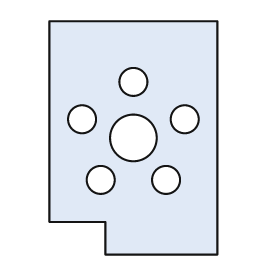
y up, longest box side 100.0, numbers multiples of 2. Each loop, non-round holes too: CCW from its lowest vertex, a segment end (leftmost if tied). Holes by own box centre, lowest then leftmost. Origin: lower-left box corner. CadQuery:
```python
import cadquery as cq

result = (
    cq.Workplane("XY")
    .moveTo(24.0, 0.0)
    .lineTo(72.0, 0.0)
    .lineTo(72.0, 100.0)
    .lineTo(0.0, 100.0)
    .lineTo(0.0, 14.0)
    .lineTo(24.0, 14.0)
    .close()
    .moveTo(22.0, 32.0)
    .circle(6.0)
    .moveTo(50.0, 32.0)
    .circle(6.0)
    .moveTo(36.0, 50.0)
    .circle(10.0)
    .moveTo(14.0, 58.0)
    .circle(6.0)
    .moveTo(58.0, 58.0)
    .circle(6.0)
    .moveTo(36.0, 74.0)
    .circle(6.0)
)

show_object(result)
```